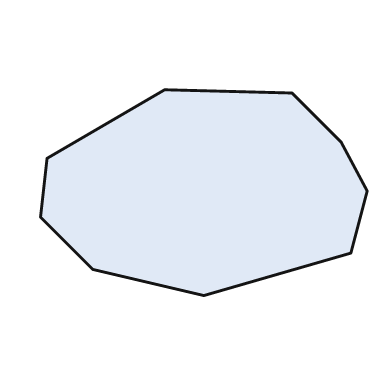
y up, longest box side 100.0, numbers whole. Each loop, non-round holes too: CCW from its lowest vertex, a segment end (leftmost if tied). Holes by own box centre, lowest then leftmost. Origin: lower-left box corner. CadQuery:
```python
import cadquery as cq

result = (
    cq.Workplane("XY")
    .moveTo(50.0, 0.0)
    .lineTo(95.0, 13.0)
    .lineTo(100.0, 32.0)
    .lineTo(92.0, 47.0)
    .lineTo(77.0, 62.0)
    .lineTo(38.0, 63.0)
    .lineTo(2.0, 42.0)
    .lineTo(0.0, 24.0)
    .lineTo(16.0, 8.0)
    .close()
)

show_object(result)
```